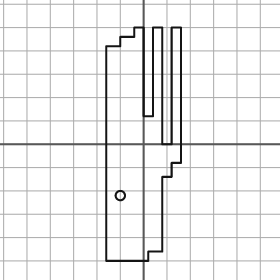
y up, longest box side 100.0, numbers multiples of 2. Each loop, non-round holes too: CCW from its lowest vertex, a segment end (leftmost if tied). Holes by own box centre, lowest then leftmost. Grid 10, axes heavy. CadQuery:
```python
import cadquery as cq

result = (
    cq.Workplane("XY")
    .moveTo(-16.0, -50.0)
    .lineTo(2.0, -50.0)
    .lineTo(2.0, -46.0)
    .lineTo(8.0, -46.0)
    .lineTo(8.0, -14.0)
    .lineTo(12.0, -14.0)
    .lineTo(12.0, -8.0)
    .lineTo(16.0, -8.0)
    .lineTo(16.0, 50.0)
    .lineTo(12.0, 50.0)
    .lineTo(12.0, 0.0)
    .lineTo(8.0, 0.0)
    .lineTo(8.0, 50.0)
    .lineTo(4.0, 50.0)
    .lineTo(4.0, 12.0)
    .lineTo(0.0, 12.0)
    .lineTo(0.0, 50.0)
    .lineTo(-4.0, 50.0)
    .lineTo(-4.0, 46.0)
    .lineTo(-10.0, 46.0)
    .lineTo(-10.0, 42.0)
    .lineTo(-16.0, 42.0)
    .close()
    .moveTo(-10.0, -22.0)
    .circle(2.0)
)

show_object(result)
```